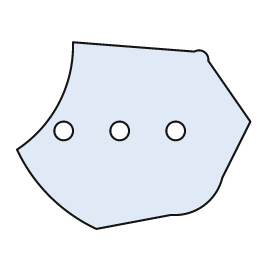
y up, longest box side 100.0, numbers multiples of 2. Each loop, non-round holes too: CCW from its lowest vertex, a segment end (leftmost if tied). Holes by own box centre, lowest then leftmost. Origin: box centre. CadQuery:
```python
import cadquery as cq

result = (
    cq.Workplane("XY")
    .moveTo(-16.0, -40.0)
    .lineTo(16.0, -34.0)
    .threePointArc((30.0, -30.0), (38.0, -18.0))
    .lineTo(50.0, 6.0)
    .lineTo(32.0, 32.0)
    .threePointArc((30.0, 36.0), (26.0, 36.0))
    .lineTo(-26.0, 40.0)
    .threePointArc((-32.0, 14.0), (-50.0, -6.0))
    .threePointArc((-36.0, -26.0), (-16.0, -40.0))
    .close()
    .moveTo(-30.0, 2.0)
    .circle(4.0)
    .moveTo(-6.0, 2.0)
    .circle(4.0)
    .moveTo(18.0, 2.0)
    .circle(4.0)
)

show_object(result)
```